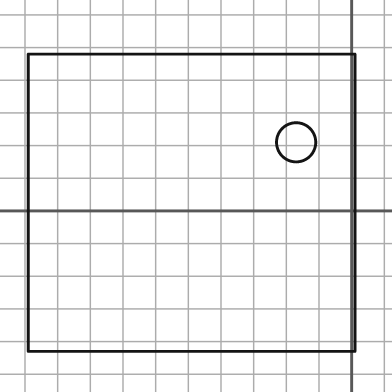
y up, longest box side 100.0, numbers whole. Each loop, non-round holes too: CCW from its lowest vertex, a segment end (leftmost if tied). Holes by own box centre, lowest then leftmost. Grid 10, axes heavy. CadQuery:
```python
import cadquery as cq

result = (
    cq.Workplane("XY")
    .moveTo(-99.0, -43.0)
    .lineTo(1.0, -43.0)
    .lineTo(1.0, 48.0)
    .lineTo(-99.0, 48.0)
    .close()
    .moveTo(-17.0, 21.0)
    .circle(6.0)
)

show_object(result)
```